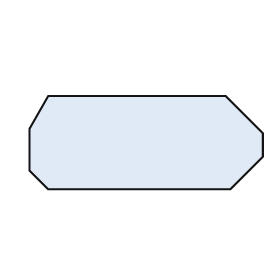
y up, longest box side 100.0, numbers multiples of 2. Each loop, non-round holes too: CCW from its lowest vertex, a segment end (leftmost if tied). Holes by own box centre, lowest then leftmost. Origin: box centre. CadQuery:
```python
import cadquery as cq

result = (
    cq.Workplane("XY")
    .moveTo(-42.0, -20.0)
    .lineTo(36.0, -20.0)
    .lineTo(50.0, -6.0)
    .lineTo(50.0, 4.0)
    .lineTo(34.0, 20.0)
    .lineTo(-42.0, 20.0)
    .lineTo(-50.0, 6.0)
    .lineTo(-50.0, -12.0)
    .close()
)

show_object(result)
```